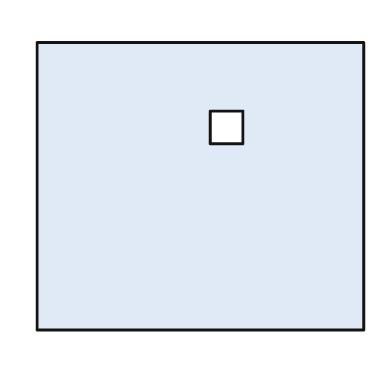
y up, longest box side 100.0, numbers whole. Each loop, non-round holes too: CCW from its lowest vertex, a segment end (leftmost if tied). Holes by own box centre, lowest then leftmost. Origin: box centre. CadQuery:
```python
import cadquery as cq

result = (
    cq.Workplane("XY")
    .moveTo(-50.0, -44.0)
    .lineTo(50.0, -44.0)
    .lineTo(50.0, 44.0)
    .lineTo(-50.0, 44.0)
    .close()
    .moveTo(3.0, 13.0)
    .lineTo(13.0, 13.0)
    .lineTo(13.0, 23.0)
    .lineTo(3.0, 23.0)
    .close()
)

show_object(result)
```